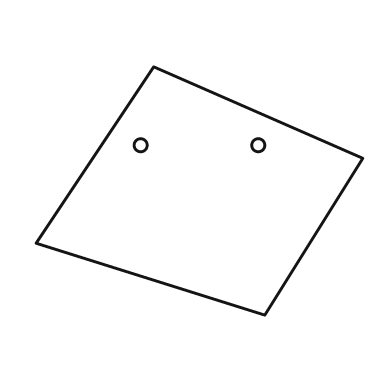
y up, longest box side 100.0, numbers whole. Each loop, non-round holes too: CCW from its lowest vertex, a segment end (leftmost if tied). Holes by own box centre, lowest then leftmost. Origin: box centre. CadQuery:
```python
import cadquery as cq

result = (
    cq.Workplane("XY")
    .moveTo(20.0, -38.0)
    .lineTo(50.0, 10.0)
    .lineTo(-14.0, 38.0)
    .lineTo(-50.0, -16.0)
    .close()
    .moveTo(-18.0, 14.0)
    .circle(2.0)
    .moveTo(18.0, 14.0)
    .circle(2.0)
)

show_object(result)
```